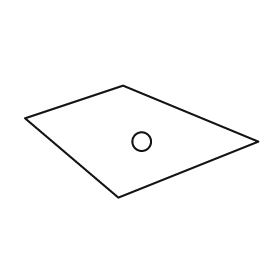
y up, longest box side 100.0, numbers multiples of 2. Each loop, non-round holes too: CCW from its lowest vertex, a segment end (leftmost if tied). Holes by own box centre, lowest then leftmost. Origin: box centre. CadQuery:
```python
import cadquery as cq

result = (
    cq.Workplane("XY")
    .moveTo(-10.0, -24.0)
    .lineTo(50.0, 0.0)
    .lineTo(-8.0, 24.0)
    .lineTo(-50.0, 10.0)
    .close()
    .moveTo(0.0, 0.0)
    .circle(4.0)
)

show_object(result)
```